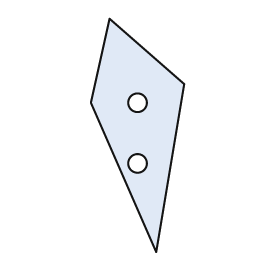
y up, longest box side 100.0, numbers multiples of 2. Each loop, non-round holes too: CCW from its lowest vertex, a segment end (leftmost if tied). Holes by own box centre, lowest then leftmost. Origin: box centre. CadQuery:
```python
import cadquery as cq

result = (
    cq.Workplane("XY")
    .moveTo(8.0, -50.0)
    .lineTo(20.0, 22.0)
    .lineTo(-12.0, 50.0)
    .lineTo(-20.0, 14.0)
    .close()
    .moveTo(0.0, -12.0)
    .circle(4.0)
    .moveTo(0.0, 14.0)
    .circle(4.0)
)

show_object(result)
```